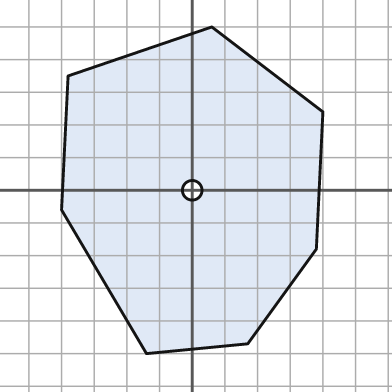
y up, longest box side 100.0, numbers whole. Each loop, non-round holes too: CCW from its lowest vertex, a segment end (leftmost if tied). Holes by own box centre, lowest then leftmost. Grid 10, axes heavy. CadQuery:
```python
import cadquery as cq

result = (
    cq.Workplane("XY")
    .moveTo(-14.0, -50.0)
    .lineTo(17.0, -47.0)
    .lineTo(38.0, -18.0)
    .lineTo(40.0, 24.0)
    .lineTo(6.0, 50.0)
    .lineTo(-38.0, 35.0)
    .lineTo(-40.0, -6.0)
    .close()
    .moveTo(0.0, 0.0)
    .circle(3.0)
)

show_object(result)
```